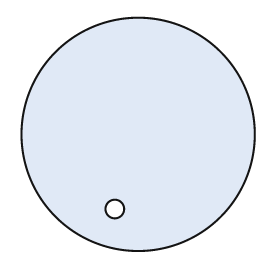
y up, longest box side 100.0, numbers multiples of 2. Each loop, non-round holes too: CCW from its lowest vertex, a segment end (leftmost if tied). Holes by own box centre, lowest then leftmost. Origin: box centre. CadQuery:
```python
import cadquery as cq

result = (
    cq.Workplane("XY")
    .moveTo(0.0, 0.0)
    .circle(50.0)
    .moveTo(-10.0, -32.0)
    .circle(4.0)
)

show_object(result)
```